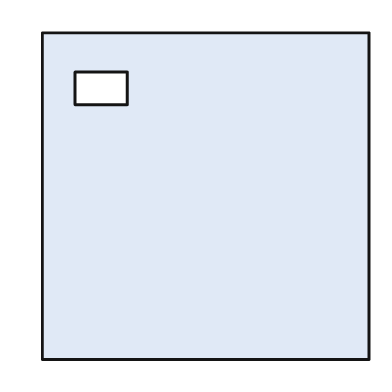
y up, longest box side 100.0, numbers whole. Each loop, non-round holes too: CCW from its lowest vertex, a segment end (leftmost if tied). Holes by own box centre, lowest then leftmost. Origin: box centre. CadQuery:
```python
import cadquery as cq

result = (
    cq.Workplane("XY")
    .moveTo(-50.0, -50.0)
    .lineTo(50.0, -50.0)
    .lineTo(50.0, 50.0)
    .lineTo(-50.0, 50.0)
    .close()
    .moveTo(-40.0, 28.0)
    .lineTo(-24.0, 28.0)
    .lineTo(-24.0, 38.0)
    .lineTo(-40.0, 38.0)
    .close()
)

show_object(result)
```